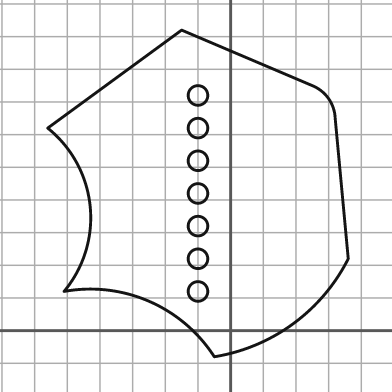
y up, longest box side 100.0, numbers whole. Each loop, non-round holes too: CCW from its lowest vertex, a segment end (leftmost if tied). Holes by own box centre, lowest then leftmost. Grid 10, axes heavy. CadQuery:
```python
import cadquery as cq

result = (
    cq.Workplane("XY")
    .moveTo(-5.0, -8.0)
    .threePointArc((19.0, 2.0), (36.0, 22.0))
    .lineTo(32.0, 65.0)
    .threePointArc((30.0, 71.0), (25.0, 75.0))
    .lineTo(-15.0, 92.0)
    .lineTo(-56.0, 62.0)
    .threePointArc((-43.0, 38.0), (-51.0, 12.0))
    .threePointArc((-25.0, 9.0), (-5.0, -8.0))
    .close()
    .moveTo(-10.0, 12.0)
    .circle(3.0)
    .moveTo(-10.0, 22.0)
    .circle(3.0)
    .moveTo(-10.0, 32.0)
    .circle(3.0)
    .moveTo(-10.0, 42.0)
    .circle(3.0)
    .moveTo(-10.0, 52.0)
    .circle(3.0)
    .moveTo(-10.0, 62.0)
    .circle(3.0)
    .moveTo(-10.0, 72.0)
    .circle(3.0)
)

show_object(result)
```